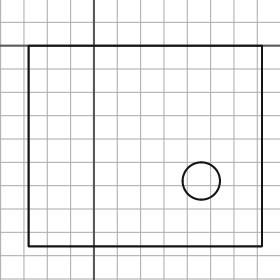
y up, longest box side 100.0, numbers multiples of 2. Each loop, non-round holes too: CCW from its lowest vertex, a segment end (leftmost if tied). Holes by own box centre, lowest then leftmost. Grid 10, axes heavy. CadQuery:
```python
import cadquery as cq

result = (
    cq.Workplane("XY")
    .moveTo(-28.0, -86.0)
    .lineTo(72.0, -86.0)
    .lineTo(72.0, 0.0)
    .lineTo(-28.0, 0.0)
    .close()
    .moveTo(46.0, -58.0)
    .circle(8.0)
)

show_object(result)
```